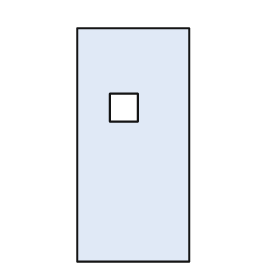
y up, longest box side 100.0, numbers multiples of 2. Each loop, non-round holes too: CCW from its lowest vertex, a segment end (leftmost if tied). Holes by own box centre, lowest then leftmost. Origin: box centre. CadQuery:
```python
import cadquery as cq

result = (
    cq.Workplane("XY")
    .moveTo(-24.0, -50.0)
    .lineTo(24.0, -50.0)
    .lineTo(24.0, 50.0)
    .lineTo(-24.0, 50.0)
    .close()
    .moveTo(-10.0, 10.0)
    .lineTo(2.0, 10.0)
    .lineTo(2.0, 22.0)
    .lineTo(-10.0, 22.0)
    .close()
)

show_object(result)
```